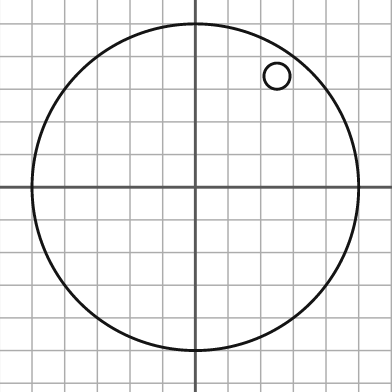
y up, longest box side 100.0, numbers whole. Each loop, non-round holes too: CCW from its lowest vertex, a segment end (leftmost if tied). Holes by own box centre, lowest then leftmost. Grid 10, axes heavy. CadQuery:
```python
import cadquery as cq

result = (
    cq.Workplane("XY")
    .moveTo(0.0, 0.0)
    .circle(50.0)
    .moveTo(25.0, 34.0)
    .circle(4.0)
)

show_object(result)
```